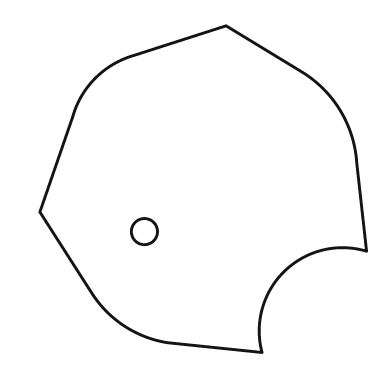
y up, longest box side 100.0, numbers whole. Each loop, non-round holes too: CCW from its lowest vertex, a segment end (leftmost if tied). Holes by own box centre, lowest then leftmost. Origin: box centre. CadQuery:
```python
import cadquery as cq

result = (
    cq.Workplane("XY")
    .moveTo(18.0, -50.0)
    .threePointArc((25.0, -25.0), (50.0, -19.0))
    .lineTo(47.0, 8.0)
    .threePointArc((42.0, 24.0), (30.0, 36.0))
    .lineTo(7.0, 50.0)
    .lineTo(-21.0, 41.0)
    .threePointArc((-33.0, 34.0), (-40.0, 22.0))
    .lineTo(-50.0, -7.0)
    .lineTo(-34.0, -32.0)
    .threePointArc((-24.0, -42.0), (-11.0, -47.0))
    .close()
    .moveTo(-18.0, -13.0)
    .circle(4.0)
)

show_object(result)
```